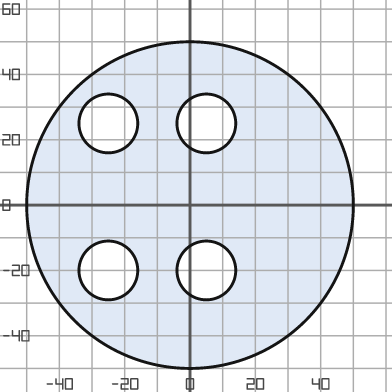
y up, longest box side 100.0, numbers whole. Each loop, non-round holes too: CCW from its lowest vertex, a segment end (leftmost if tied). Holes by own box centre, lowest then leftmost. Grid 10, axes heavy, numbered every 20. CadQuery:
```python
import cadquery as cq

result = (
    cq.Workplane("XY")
    .moveTo(0.0, 0.0)
    .circle(50.0)
    .moveTo(-25.0, -20.0)
    .circle(9.0)
    .moveTo(5.0, -20.0)
    .circle(9.0)
    .moveTo(-25.0, 25.0)
    .circle(9.0)
    .moveTo(5.0, 25.0)
    .circle(9.0)
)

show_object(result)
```